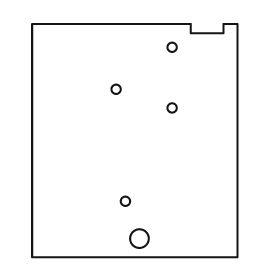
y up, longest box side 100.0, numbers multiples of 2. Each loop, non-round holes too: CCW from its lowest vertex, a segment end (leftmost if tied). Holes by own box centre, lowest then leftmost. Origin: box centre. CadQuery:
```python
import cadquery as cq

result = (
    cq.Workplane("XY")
    .moveTo(-44.0, -50.0)
    .lineTo(44.0, -50.0)
    .lineTo(44.0, 50.0)
    .lineTo(38.0, 50.0)
    .lineTo(38.0, 46.0)
    .lineTo(24.0, 46.0)
    .lineTo(24.0, 50.0)
    .lineTo(-44.0, 50.0)
    .close()
    .moveTo(2.0, -42.0)
    .circle(4.0)
    .moveTo(-4.0, -26.0)
    .circle(2.0)
    .moveTo(16.0, 14.0)
    .circle(2.0)
    .moveTo(-8.0, 22.0)
    .circle(2.0)
    .moveTo(16.0, 40.0)
    .circle(2.0)
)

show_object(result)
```